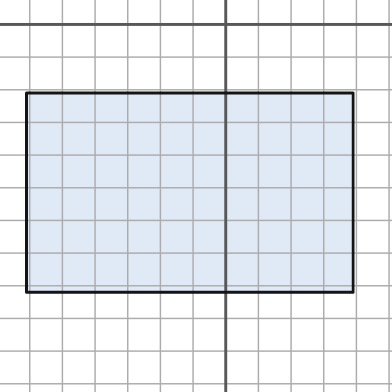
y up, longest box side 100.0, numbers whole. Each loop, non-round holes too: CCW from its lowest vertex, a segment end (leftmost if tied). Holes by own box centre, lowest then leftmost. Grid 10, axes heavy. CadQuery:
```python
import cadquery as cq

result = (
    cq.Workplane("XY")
    .moveTo(-61.0, -82.0)
    .lineTo(39.0, -82.0)
    .lineTo(39.0, -21.0)
    .lineTo(-61.0, -21.0)
    .close()
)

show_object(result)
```